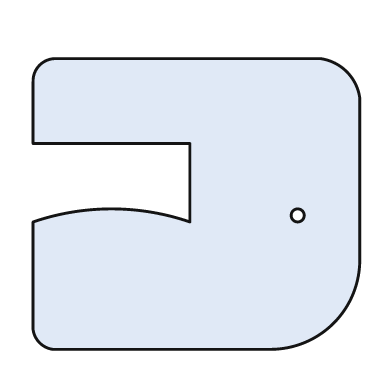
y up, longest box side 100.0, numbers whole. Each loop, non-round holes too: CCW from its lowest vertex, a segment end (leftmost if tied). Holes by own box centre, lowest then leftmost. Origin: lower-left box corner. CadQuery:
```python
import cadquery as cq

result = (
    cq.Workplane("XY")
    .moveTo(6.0, 0.0)
    .lineTo(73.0, 0.0)
    .threePointArc((92.0, 8.0), (100.0, 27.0))
    .lineTo(100.0, 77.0)
    .threePointArc((96.0, 85.0), (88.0, 89.0))
    .lineTo(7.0, 89.0)
    .threePointArc((2.0, 87.0), (0.0, 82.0))
    .lineTo(0.0, 63.0)
    .lineTo(48.0, 63.0)
    .lineTo(48.0, 39.0)
    .threePointArc((24.0, 43.0), (0.0, 39.0))
    .lineTo(0.0, 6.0)
    .threePointArc((2.0, 2.0), (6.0, 0.0))
    .close()
    .moveTo(81.0, 41.0)
    .circle(2.0)
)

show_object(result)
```